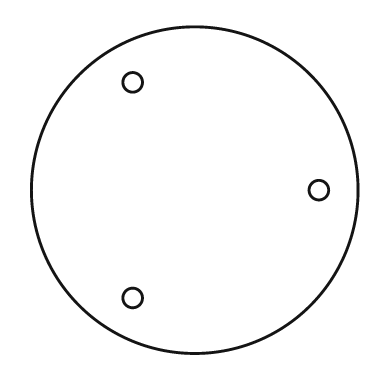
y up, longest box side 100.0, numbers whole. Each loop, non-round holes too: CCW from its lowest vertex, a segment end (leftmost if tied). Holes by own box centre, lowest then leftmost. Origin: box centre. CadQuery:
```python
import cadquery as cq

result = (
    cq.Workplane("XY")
    .moveTo(0.0, 0.0)
    .circle(50.0)
    .moveTo(-19.0, -33.0)
    .circle(3.0)
    .moveTo(38.0, 0.0)
    .circle(3.0)
    .moveTo(-19.0, 33.0)
    .circle(3.0)
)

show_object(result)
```